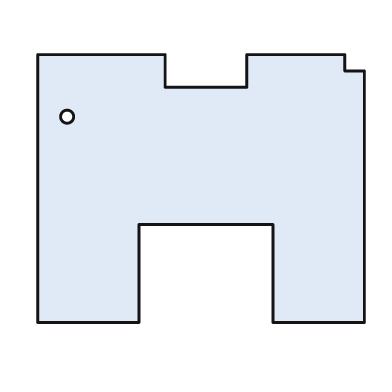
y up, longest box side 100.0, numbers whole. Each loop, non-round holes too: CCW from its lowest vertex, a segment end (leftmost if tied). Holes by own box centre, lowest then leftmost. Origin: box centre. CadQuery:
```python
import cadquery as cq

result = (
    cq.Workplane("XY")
    .moveTo(-50.0, -41.0)
    .lineTo(-19.0, -41.0)
    .lineTo(-19.0, -11.0)
    .lineTo(22.0, -11.0)
    .lineTo(22.0, -41.0)
    .lineTo(50.0, -41.0)
    .lineTo(50.0, 36.0)
    .lineTo(44.0, 36.0)
    .lineTo(44.0, 41.0)
    .lineTo(14.0, 41.0)
    .lineTo(14.0, 31.0)
    .lineTo(-11.0, 31.0)
    .lineTo(-11.0, 41.0)
    .lineTo(-50.0, 41.0)
    .close()
    .moveTo(-41.0, 22.0)
    .circle(2.0)
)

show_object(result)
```